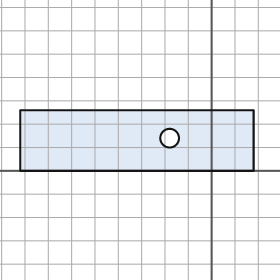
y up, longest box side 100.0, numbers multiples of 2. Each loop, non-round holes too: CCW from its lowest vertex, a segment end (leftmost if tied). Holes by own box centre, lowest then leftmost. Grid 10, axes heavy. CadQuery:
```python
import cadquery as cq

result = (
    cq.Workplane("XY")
    .moveTo(-82.0, 0.0)
    .lineTo(18.0, 0.0)
    .lineTo(18.0, 26.0)
    .lineTo(-82.0, 26.0)
    .close()
    .moveTo(-18.0, 14.0)
    .circle(4.0)
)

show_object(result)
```